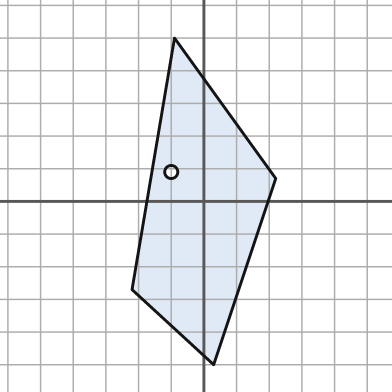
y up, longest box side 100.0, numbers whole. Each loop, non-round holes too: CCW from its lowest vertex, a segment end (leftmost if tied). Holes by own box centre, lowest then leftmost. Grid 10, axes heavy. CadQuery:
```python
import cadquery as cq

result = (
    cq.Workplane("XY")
    .moveTo(3.0, -50.0)
    .lineTo(22.0, 7.0)
    .lineTo(-9.0, 50.0)
    .lineTo(-22.0, -27.0)
    .close()
    .moveTo(-10.0, 9.0)
    .circle(2.0)
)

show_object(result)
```